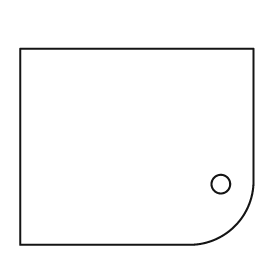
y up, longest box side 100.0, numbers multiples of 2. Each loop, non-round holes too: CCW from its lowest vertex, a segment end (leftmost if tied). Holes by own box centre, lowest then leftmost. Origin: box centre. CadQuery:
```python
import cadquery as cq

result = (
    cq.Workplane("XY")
    .moveTo(-50.0, -42.0)
    .lineTo(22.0, -42.0)
    .threePointArc((42.0, -34.0), (50.0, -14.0))
    .lineTo(50.0, 42.0)
    .lineTo(-50.0, 42.0)
    .close()
    .moveTo(36.0, -16.0)
    .circle(4.0)
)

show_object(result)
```